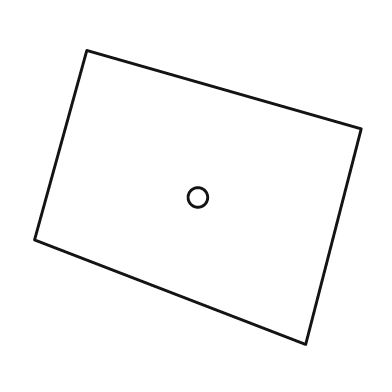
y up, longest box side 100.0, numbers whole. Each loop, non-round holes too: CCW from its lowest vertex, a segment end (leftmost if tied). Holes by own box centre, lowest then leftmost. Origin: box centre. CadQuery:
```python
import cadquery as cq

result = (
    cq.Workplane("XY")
    .moveTo(33.0, -45.0)
    .lineTo(50.0, 21.0)
    .lineTo(-34.0, 45.0)
    .lineTo(-50.0, -13.0)
    .close()
    .moveTo(0.0, 0.0)
    .circle(3.0)
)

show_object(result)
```